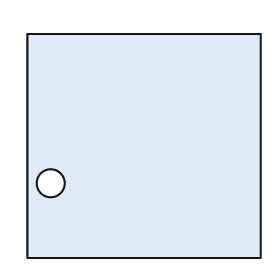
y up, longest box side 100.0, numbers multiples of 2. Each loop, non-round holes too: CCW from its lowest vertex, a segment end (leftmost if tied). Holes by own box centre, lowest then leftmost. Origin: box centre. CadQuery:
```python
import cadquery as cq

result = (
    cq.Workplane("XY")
    .moveTo(-50.0, -48.0)
    .lineTo(50.0, -48.0)
    .lineTo(50.0, 48.0)
    .lineTo(-50.0, 48.0)
    .close()
    .moveTo(-40.0, -16.0)
    .circle(6.0)
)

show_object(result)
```